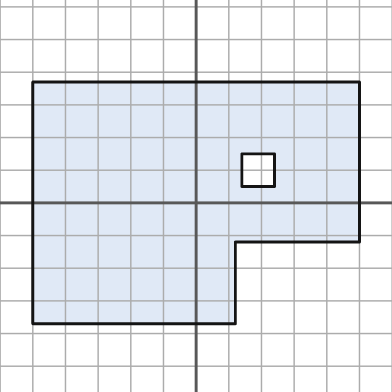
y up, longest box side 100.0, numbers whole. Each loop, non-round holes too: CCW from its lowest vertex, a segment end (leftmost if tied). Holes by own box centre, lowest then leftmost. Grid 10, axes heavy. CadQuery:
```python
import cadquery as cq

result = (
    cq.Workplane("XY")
    .moveTo(-50.0, -37.0)
    .lineTo(12.0, -37.0)
    .lineTo(12.0, -12.0)
    .lineTo(50.0, -12.0)
    .lineTo(50.0, 37.0)
    .lineTo(-50.0, 37.0)
    .close()
    .moveTo(14.0, 5.0)
    .lineTo(24.0, 5.0)
    .lineTo(24.0, 15.0)
    .lineTo(14.0, 15.0)
    .close()
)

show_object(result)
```